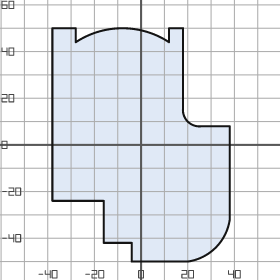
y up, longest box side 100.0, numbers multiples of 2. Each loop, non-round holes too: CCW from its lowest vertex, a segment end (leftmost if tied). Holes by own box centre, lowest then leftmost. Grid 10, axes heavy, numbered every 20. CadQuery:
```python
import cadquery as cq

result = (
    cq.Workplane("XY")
    .moveTo(-4.0, -50.0)
    .lineTo(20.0, -50.0)
    .threePointArc((32.0, -44.0), (38.0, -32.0))
    .lineTo(38.0, 8.0)
    .lineTo(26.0, 8.0)
    .threePointArc((20.0, 10.0), (18.0, 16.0))
    .lineTo(18.0, 50.0)
    .lineTo(12.0, 50.0)
    .lineTo(12.0, 44.0)
    .threePointArc((-8.0, 50.0), (-28.0, 44.0))
    .lineTo(-28.0, 50.0)
    .lineTo(-38.0, 50.0)
    .lineTo(-38.0, -24.0)
    .lineTo(-16.0, -24.0)
    .lineTo(-16.0, -42.0)
    .lineTo(-4.0, -42.0)
    .close()
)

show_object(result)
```